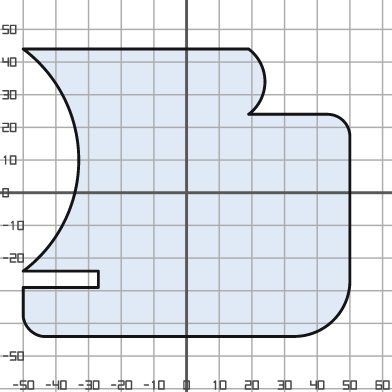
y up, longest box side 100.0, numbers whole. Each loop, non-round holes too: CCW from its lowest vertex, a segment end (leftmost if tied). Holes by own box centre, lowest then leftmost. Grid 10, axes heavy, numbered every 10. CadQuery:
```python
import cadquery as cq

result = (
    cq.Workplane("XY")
    .moveTo(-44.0, -44.0)
    .lineTo(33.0, -44.0)
    .threePointArc((45.0, -39.0), (50.0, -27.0))
    .lineTo(50.0, 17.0)
    .threePointArc((48.0, 22.0), (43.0, 24.0))
    .lineTo(19.0, 24.0)
    .threePointArc((24.0, 34.0), (19.0, 44.0))
    .lineTo(-50.0, 44.0)
    .threePointArc((-33.0, 10.0), (-50.0, -24.0))
    .lineTo(-27.0, -24.0)
    .lineTo(-27.0, -29.0)
    .lineTo(-50.0, -29.0)
    .lineTo(-50.0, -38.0)
    .threePointArc((-48.0, -42.0), (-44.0, -44.0))
    .close()
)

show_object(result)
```